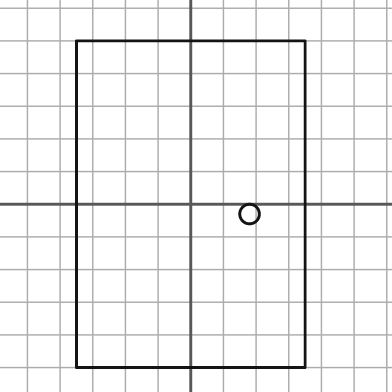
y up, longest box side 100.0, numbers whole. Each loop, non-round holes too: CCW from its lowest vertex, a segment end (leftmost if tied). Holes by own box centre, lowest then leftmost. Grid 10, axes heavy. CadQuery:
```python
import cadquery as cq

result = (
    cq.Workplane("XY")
    .moveTo(-35.0, -50.0)
    .lineTo(35.0, -50.0)
    .lineTo(35.0, 50.0)
    .lineTo(-35.0, 50.0)
    .close()
    .moveTo(18.0, -3.0)
    .circle(3.0)
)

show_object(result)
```